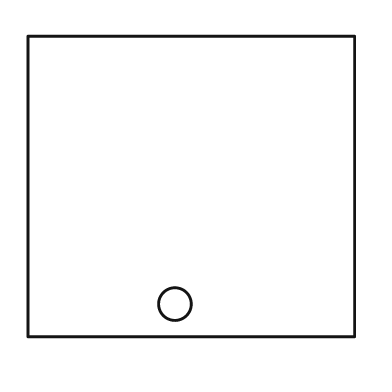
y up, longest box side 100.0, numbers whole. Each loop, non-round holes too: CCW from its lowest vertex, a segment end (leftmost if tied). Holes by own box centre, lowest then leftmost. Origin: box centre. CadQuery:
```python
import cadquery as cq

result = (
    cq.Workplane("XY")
    .moveTo(-50.0, -46.0)
    .lineTo(50.0, -46.0)
    .lineTo(50.0, 46.0)
    .lineTo(-50.0, 46.0)
    .close()
    .moveTo(-5.0, -36.0)
    .circle(5.0)
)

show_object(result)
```